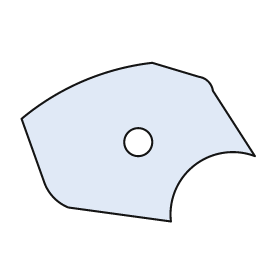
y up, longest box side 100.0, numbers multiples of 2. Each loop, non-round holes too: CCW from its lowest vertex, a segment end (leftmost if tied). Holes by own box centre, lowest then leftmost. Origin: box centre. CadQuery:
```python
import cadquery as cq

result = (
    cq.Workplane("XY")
    .moveTo(14.0, -34.0)
    .threePointArc((24.0, -10.0), (50.0, -6.0))
    .lineTo(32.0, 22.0)
    .threePointArc((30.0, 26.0), (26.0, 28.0))
    .lineTo(6.0, 34.0)
    .threePointArc((-24.0, 26.0), (-50.0, 10.0))
    .lineTo(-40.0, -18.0)
    .threePointArc((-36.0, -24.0), (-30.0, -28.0))
    .close()
    .moveTo(0.0, 0.0)
    .circle(6.0)
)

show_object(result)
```